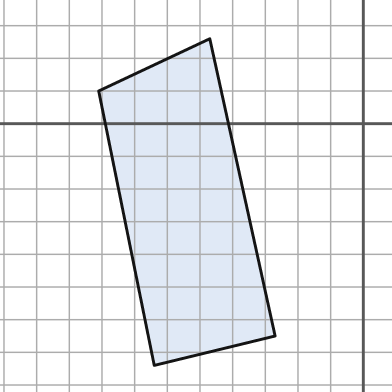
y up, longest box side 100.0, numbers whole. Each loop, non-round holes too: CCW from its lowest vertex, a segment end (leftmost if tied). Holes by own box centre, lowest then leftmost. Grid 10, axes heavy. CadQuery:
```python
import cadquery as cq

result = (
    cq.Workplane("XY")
    .moveTo(-64.0, -74.0)
    .lineTo(-27.0, -65.0)
    .lineTo(-47.0, 26.0)
    .lineTo(-81.0, 10.0)
    .close()
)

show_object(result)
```